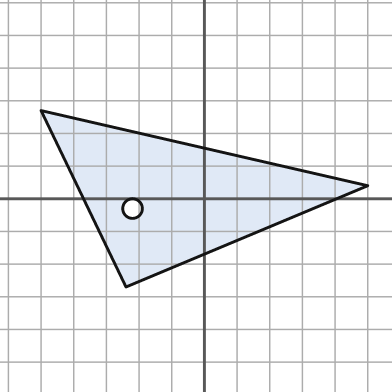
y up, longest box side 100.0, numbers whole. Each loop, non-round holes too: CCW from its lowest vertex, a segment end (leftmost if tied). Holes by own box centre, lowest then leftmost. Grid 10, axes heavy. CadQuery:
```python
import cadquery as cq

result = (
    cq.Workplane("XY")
    .moveTo(-24.0, -27.0)
    .lineTo(50.0, 4.0)
    .lineTo(-50.0, 27.0)
    .close()
    .moveTo(-22.0, -3.0)
    .circle(3.0)
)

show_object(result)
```